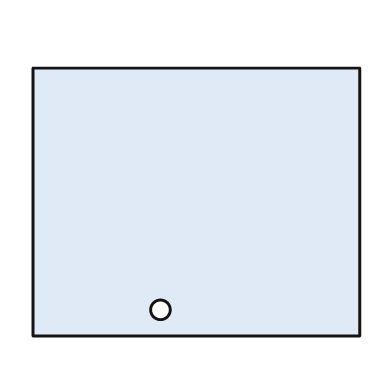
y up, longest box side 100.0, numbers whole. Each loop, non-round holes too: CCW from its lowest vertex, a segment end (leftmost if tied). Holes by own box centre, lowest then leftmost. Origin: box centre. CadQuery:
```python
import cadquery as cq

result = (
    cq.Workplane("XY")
    .moveTo(-50.0, -41.0)
    .lineTo(50.0, -41.0)
    .lineTo(50.0, 41.0)
    .lineTo(-50.0, 41.0)
    .close()
    .moveTo(-11.0, -33.0)
    .circle(3.0)
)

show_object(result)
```